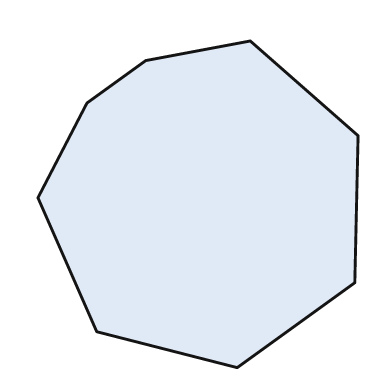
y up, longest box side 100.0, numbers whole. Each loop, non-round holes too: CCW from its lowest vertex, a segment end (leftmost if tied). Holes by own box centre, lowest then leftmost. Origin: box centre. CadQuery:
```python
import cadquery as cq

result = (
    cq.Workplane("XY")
    .moveTo(12.0, -50.0)
    .lineTo(48.0, -24.0)
    .lineTo(49.0, 21.0)
    .lineTo(16.0, 50.0)
    .lineTo(-16.0, 44.0)
    .lineTo(-34.0, 31.0)
    .lineTo(-49.0, 2.0)
    .lineTo(-31.0, -39.0)
    .close()
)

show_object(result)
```